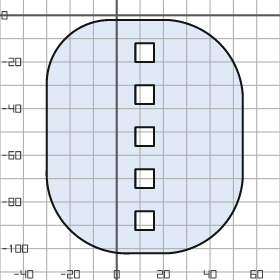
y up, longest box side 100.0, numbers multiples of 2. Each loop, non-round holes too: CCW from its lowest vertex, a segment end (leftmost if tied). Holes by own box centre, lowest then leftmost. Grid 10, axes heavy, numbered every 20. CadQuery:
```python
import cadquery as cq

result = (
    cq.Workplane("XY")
    .moveTo(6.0, -102.0)
    .lineTo(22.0, -102.0)
    .threePointArc((44.0, -92.0), (54.0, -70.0))
    .lineTo(54.0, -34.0)
    .threePointArc((44.0, -12.0), (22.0, -2.0))
    .lineTo(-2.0, -2.0)
    .threePointArc((-22.0, -10.0), (-30.0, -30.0))
    .lineTo(-30.0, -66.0)
    .threePointArc((-20.0, -92.0), (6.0, -102.0))
    .close()
    .moveTo(8.0, -92.0)
    .lineTo(16.0, -92.0)
    .lineTo(16.0, -84.0)
    .lineTo(8.0, -84.0)
    .close()
    .moveTo(8.0, -74.0)
    .lineTo(16.0, -74.0)
    .lineTo(16.0, -66.0)
    .lineTo(8.0, -66.0)
    .close()
    .moveTo(8.0, -56.0)
    .lineTo(16.0, -56.0)
    .lineTo(16.0, -48.0)
    .lineTo(8.0, -48.0)
    .close()
    .moveTo(8.0, -38.0)
    .lineTo(16.0, -38.0)
    .lineTo(16.0, -30.0)
    .lineTo(8.0, -30.0)
    .close()
    .moveTo(8.0, -20.0)
    .lineTo(16.0, -20.0)
    .lineTo(16.0, -12.0)
    .lineTo(8.0, -12.0)
    .close()
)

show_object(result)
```